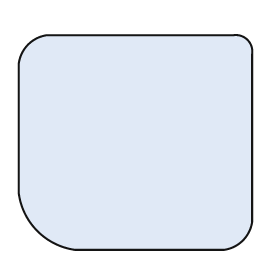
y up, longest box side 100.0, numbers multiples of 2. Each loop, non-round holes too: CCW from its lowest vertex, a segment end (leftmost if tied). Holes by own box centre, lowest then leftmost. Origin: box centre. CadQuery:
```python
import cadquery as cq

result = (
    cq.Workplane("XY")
    .moveTo(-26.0, -46.0)
    .lineTo(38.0, -46.0)
    .threePointArc((46.0, -42.0), (50.0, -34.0))
    .lineTo(50.0, 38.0)
    .threePointArc((48.0, 44.0), (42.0, 46.0))
    .lineTo(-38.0, 46.0)
    .threePointArc((-46.0, 42.0), (-50.0, 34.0))
    .lineTo(-50.0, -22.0)
    .threePointArc((-42.0, -38.0), (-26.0, -46.0))
    .close()
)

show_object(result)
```